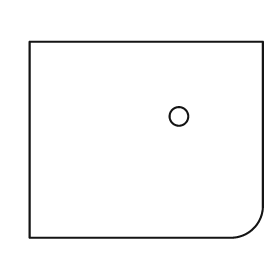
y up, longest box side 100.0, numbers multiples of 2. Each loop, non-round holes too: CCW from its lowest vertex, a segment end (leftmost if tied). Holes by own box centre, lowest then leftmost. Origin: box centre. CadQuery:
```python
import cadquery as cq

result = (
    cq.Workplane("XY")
    .moveTo(-50.0, -42.0)
    .lineTo(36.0, -42.0)
    .threePointArc((46.0, -38.0), (50.0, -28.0))
    .lineTo(50.0, 42.0)
    .lineTo(-50.0, 42.0)
    .close()
    .moveTo(14.0, 10.0)
    .circle(4.0)
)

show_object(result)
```